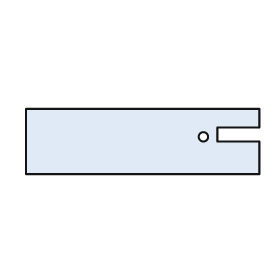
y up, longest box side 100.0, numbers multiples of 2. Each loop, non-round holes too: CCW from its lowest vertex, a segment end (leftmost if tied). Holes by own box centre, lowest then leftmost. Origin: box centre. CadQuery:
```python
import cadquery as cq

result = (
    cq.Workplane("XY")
    .moveTo(-50.0, -14.0)
    .lineTo(50.0, -14.0)
    .lineTo(50.0, 0.0)
    .lineTo(32.0, 0.0)
    .lineTo(32.0, 6.0)
    .lineTo(50.0, 6.0)
    .lineTo(50.0, 14.0)
    .lineTo(-50.0, 14.0)
    .close()
    .moveTo(26.0, 2.0)
    .circle(2.0)
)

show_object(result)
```